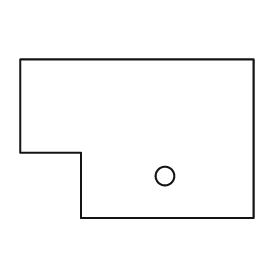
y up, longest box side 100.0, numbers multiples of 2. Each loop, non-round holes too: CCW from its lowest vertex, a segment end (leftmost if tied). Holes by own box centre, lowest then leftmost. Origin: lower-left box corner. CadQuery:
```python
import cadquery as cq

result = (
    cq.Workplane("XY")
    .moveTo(26.0, 0.0)
    .lineTo(100.0, 0.0)
    .lineTo(100.0, 68.0)
    .lineTo(0.0, 68.0)
    .lineTo(0.0, 28.0)
    .lineTo(26.0, 28.0)
    .close()
    .moveTo(62.0, 18.0)
    .circle(4.0)
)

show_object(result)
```